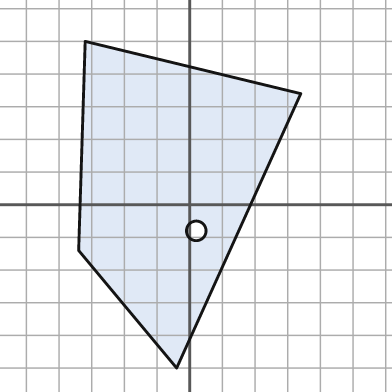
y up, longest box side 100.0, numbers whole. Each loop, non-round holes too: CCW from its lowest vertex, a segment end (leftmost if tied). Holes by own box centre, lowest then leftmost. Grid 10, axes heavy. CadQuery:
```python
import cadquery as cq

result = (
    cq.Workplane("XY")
    .moveTo(-4.0, -50.0)
    .lineTo(34.0, 34.0)
    .lineTo(-32.0, 50.0)
    .lineTo(-34.0, -14.0)
    .close()
    .moveTo(2.0, -8.0)
    .circle(3.0)
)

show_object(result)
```